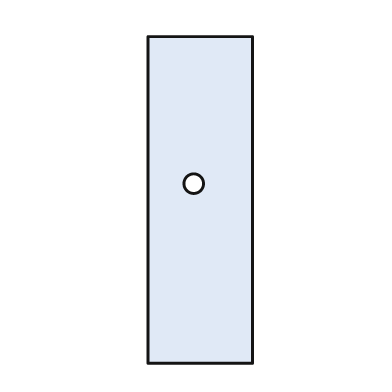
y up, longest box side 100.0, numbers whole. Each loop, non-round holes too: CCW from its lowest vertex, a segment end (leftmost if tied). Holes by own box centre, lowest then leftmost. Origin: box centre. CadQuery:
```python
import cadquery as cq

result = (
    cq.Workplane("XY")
    .moveTo(-16.0, -50.0)
    .lineTo(16.0, -50.0)
    .lineTo(16.0, 50.0)
    .lineTo(-16.0, 50.0)
    .close()
    .moveTo(-2.0, 5.0)
    .circle(3.0)
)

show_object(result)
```